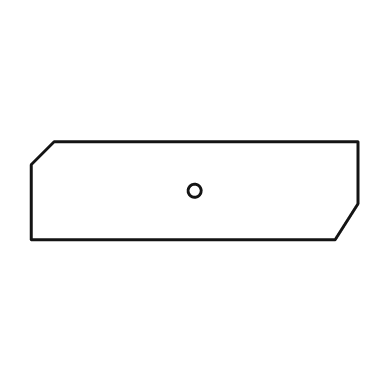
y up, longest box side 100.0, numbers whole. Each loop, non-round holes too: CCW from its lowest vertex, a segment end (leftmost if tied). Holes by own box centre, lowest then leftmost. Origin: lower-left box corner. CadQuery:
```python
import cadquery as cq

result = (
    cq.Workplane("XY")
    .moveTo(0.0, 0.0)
    .lineTo(93.0, 0.0)
    .lineTo(100.0, 11.0)
    .lineTo(100.0, 30.0)
    .lineTo(7.0, 30.0)
    .lineTo(0.0, 23.0)
    .close()
    .moveTo(50.0, 15.0)
    .circle(2.0)
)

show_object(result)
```